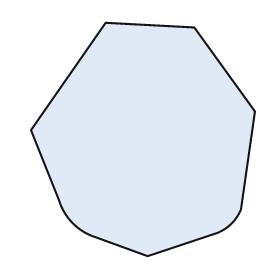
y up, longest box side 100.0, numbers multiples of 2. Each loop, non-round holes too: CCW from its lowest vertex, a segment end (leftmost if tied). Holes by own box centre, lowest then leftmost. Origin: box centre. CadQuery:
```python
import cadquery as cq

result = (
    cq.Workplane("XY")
    .moveTo(2.0, -50.0)
    .lineTo(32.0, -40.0)
    .threePointArc((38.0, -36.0), (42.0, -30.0))
    .lineTo(48.0, 12.0)
    .lineTo(22.0, 48.0)
    .lineTo(-16.0, 50.0)
    .lineTo(-48.0, 4.0)
    .lineTo(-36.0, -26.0)
    .threePointArc((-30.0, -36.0), (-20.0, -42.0))
    .close()
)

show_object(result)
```